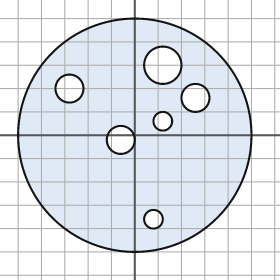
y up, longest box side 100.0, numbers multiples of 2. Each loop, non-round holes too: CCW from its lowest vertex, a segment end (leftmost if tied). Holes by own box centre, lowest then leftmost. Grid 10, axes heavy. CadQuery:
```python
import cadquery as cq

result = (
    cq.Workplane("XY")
    .moveTo(0.0, 0.0)
    .circle(50.0)
    .moveTo(8.0, -36.0)
    .circle(4.0)
    .moveTo(-6.0, -2.0)
    .circle(6.0)
    .moveTo(12.0, 6.0)
    .circle(4.0)
    .moveTo(26.0, 16.0)
    .circle(6.0)
    .moveTo(-28.0, 20.0)
    .circle(6.0)
    .moveTo(12.0, 30.0)
    .circle(8.0)
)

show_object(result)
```